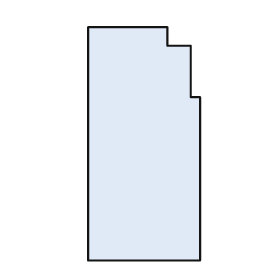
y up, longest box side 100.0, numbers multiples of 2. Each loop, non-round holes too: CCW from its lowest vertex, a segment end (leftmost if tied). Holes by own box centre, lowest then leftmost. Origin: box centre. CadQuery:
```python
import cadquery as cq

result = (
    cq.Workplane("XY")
    .moveTo(-24.0, -50.0)
    .lineTo(24.0, -50.0)
    .lineTo(24.0, 20.0)
    .lineTo(20.0, 20.0)
    .lineTo(20.0, 42.0)
    .lineTo(10.0, 42.0)
    .lineTo(10.0, 50.0)
    .lineTo(-24.0, 50.0)
    .close()
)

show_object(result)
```